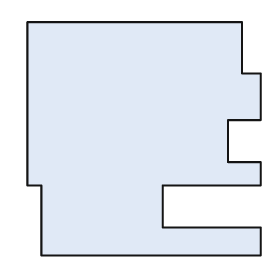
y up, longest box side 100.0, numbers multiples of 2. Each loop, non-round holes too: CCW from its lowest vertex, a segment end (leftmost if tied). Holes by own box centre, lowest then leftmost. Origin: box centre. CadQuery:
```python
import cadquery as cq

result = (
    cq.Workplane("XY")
    .moveTo(-44.0, -50.0)
    .lineTo(50.0, -50.0)
    .lineTo(50.0, -38.0)
    .lineTo(8.0, -38.0)
    .lineTo(8.0, -20.0)
    .lineTo(50.0, -20.0)
    .lineTo(50.0, -10.0)
    .lineTo(36.0, -10.0)
    .lineTo(36.0, 8.0)
    .lineTo(50.0, 8.0)
    .lineTo(50.0, 28.0)
    .lineTo(42.0, 28.0)
    .lineTo(42.0, 50.0)
    .lineTo(-50.0, 50.0)
    .lineTo(-50.0, -20.0)
    .lineTo(-44.0, -20.0)
    .close()
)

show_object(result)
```